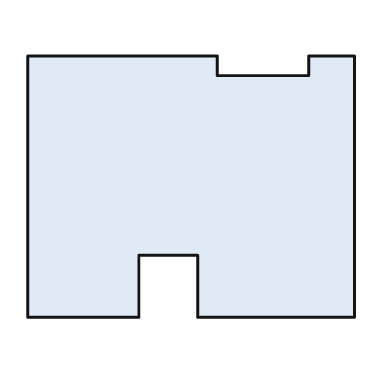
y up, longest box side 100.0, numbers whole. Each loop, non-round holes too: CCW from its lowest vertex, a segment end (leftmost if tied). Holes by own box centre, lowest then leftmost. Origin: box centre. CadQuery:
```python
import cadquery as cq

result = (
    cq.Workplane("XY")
    .moveTo(-50.0, -40.0)
    .lineTo(-16.0, -40.0)
    .lineTo(-16.0, -21.0)
    .lineTo(2.0, -21.0)
    .lineTo(2.0, -40.0)
    .lineTo(50.0, -40.0)
    .lineTo(50.0, 40.0)
    .lineTo(36.0, 40.0)
    .lineTo(36.0, 34.0)
    .lineTo(8.0, 34.0)
    .lineTo(8.0, 40.0)
    .lineTo(-50.0, 40.0)
    .close()
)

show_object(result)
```